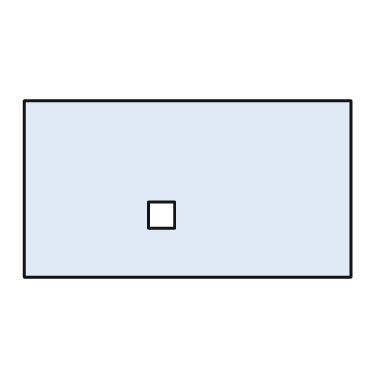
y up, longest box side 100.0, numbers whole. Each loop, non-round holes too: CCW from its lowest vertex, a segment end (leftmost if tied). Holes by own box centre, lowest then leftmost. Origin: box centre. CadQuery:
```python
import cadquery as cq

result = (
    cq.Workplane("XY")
    .moveTo(-50.0, -27.0)
    .lineTo(50.0, -27.0)
    .lineTo(50.0, 27.0)
    .lineTo(-50.0, 27.0)
    .close()
    .moveTo(-12.0, -12.0)
    .lineTo(-4.0, -12.0)
    .lineTo(-4.0, -4.0)
    .lineTo(-12.0, -4.0)
    .close()
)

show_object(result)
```